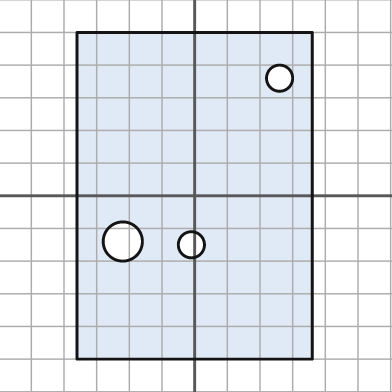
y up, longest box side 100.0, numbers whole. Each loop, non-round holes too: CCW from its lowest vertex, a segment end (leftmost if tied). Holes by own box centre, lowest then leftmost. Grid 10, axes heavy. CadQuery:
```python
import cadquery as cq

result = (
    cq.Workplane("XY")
    .moveTo(-36.0, -50.0)
    .lineTo(36.0, -50.0)
    .lineTo(36.0, 50.0)
    .lineTo(-36.0, 50.0)
    .close()
    .moveTo(-1.0, -15.0)
    .circle(4.0)
    .moveTo(-22.0, -14.0)
    .circle(6.0)
    .moveTo(26.0, 36.0)
    .circle(4.0)
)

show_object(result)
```